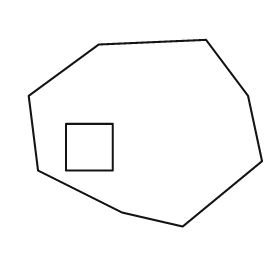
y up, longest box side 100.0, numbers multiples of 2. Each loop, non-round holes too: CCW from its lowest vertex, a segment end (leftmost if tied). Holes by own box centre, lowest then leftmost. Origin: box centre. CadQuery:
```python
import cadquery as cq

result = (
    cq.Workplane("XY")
    .moveTo(16.0, -40.0)
    .lineTo(50.0, -12.0)
    .lineTo(44.0, 16.0)
    .lineTo(26.0, 40.0)
    .lineTo(-20.0, 38.0)
    .lineTo(-50.0, 16.0)
    .lineTo(-46.0, -16.0)
    .lineTo(-10.0, -34.0)
    .close()
    .moveTo(-34.0, -16.0)
    .lineTo(-14.0, -16.0)
    .lineTo(-14.0, 4.0)
    .lineTo(-34.0, 4.0)
    .close()
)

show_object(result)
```